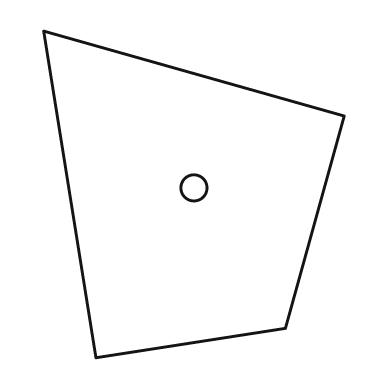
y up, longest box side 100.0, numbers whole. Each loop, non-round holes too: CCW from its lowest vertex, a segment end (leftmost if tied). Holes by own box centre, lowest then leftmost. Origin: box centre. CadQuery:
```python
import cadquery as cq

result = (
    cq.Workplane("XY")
    .moveTo(-30.0, -50.0)
    .lineTo(28.0, -41.0)
    .lineTo(46.0, 24.0)
    .lineTo(-46.0, 50.0)
    .close()
    .moveTo(0.0, 2.0)
    .circle(4.0)
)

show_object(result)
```